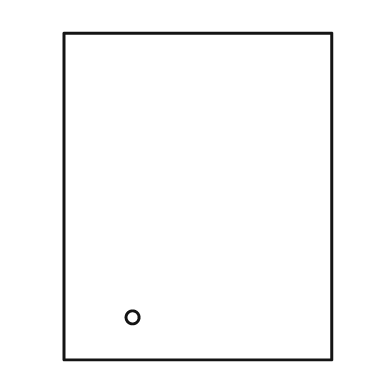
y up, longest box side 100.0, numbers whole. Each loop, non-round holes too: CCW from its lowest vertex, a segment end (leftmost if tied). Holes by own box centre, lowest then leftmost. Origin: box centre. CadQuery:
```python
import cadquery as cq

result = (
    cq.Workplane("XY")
    .moveTo(-41.0, -50.0)
    .lineTo(41.0, -50.0)
    .lineTo(41.0, 50.0)
    .lineTo(-41.0, 50.0)
    .close()
    .moveTo(-20.0, -37.0)
    .circle(2.0)
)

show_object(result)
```